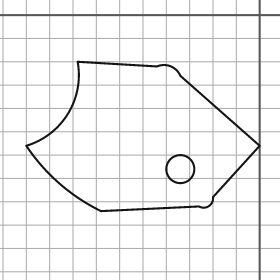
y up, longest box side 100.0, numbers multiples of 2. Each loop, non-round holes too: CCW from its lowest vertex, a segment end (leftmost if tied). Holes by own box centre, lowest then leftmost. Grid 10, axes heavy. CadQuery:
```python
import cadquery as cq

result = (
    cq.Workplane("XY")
    .moveTo(-68.0, -84.0)
    .lineTo(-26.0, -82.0)
    .threePointArc((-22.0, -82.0), (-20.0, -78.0))
    .lineTo(0.0, -56.0)
    .lineTo(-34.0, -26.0)
    .threePointArc((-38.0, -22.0), (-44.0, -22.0))
    .lineTo(-78.0, -20.0)
    .threePointArc((-82.0, -42.0), (-100.0, -56.0))
    .threePointArc((-86.0, -72.0), (-68.0, -84.0))
    .close()
    .moveTo(-34.0, -66.0)
    .circle(6.0)
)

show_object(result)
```